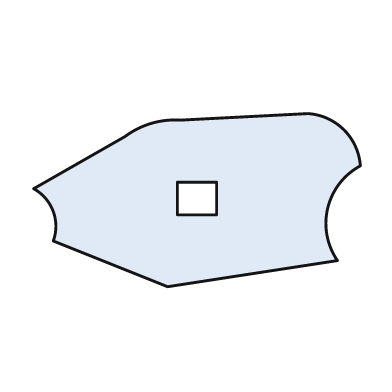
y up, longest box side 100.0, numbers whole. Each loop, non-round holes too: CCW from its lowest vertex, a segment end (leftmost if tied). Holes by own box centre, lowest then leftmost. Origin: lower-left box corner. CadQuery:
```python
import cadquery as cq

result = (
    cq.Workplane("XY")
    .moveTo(41.0, 0.0)
    .lineTo(93.0, 8.0)
    .threePointArc((90.0, 24.0), (100.0, 37.0))
    .threePointArc((95.0, 48.0), (84.0, 53.0))
    .lineTo(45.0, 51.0)
    .threePointArc((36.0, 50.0), (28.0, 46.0))
    .lineTo(0.0, 30.0)
    .threePointArc((6.0, 23.0), (6.0, 14.0))
    .close()
    .moveTo(44.0, 22.0)
    .lineTo(56.0, 22.0)
    .lineTo(56.0, 32.0)
    .lineTo(44.0, 32.0)
    .close()
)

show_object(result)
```